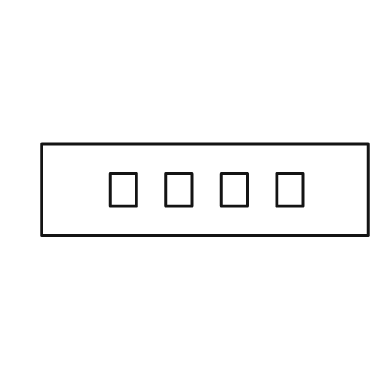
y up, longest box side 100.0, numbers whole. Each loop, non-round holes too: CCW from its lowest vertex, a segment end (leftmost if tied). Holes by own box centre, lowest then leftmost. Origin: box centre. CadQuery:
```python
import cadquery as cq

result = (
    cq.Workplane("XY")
    .moveTo(-50.0, -14.0)
    .lineTo(50.0, -14.0)
    .lineTo(50.0, 14.0)
    .lineTo(-50.0, 14.0)
    .close()
    .moveTo(-29.0, -5.0)
    .lineTo(-21.0, -5.0)
    .lineTo(-21.0, 5.0)
    .lineTo(-29.0, 5.0)
    .close()
    .moveTo(-12.0, -5.0)
    .lineTo(-4.0, -5.0)
    .lineTo(-4.0, 5.0)
    .lineTo(-12.0, 5.0)
    .close()
    .moveTo(5.0, -5.0)
    .lineTo(13.0, -5.0)
    .lineTo(13.0, 5.0)
    .lineTo(5.0, 5.0)
    .close()
    .moveTo(22.0, -5.0)
    .lineTo(30.0, -5.0)
    .lineTo(30.0, 5.0)
    .lineTo(22.0, 5.0)
    .close()
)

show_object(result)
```